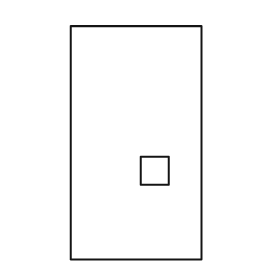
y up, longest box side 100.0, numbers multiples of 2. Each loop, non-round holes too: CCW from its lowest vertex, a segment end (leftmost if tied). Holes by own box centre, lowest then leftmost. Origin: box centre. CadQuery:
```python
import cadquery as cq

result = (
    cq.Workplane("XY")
    .moveTo(-28.0, -50.0)
    .lineTo(28.0, -50.0)
    .lineTo(28.0, 50.0)
    .lineTo(-28.0, 50.0)
    .close()
    .moveTo(2.0, -18.0)
    .lineTo(14.0, -18.0)
    .lineTo(14.0, -6.0)
    .lineTo(2.0, -6.0)
    .close()
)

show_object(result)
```